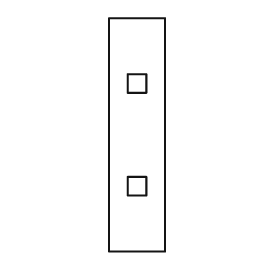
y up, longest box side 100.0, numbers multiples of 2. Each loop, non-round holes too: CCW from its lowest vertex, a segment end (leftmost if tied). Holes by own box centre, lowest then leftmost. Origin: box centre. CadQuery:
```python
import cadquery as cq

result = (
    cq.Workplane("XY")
    .moveTo(-12.0, -50.0)
    .lineTo(12.0, -50.0)
    .lineTo(12.0, 50.0)
    .lineTo(-12.0, 50.0)
    .close()
    .moveTo(-4.0, -26.0)
    .lineTo(4.0, -26.0)
    .lineTo(4.0, -18.0)
    .lineTo(-4.0, -18.0)
    .close()
    .moveTo(-4.0, 18.0)
    .lineTo(4.0, 18.0)
    .lineTo(4.0, 26.0)
    .lineTo(-4.0, 26.0)
    .close()
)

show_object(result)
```